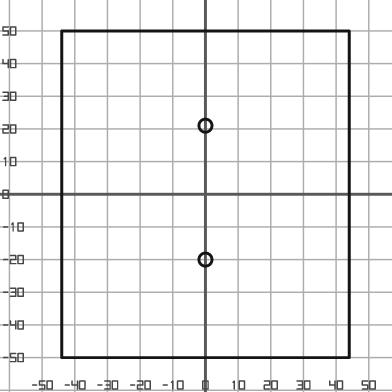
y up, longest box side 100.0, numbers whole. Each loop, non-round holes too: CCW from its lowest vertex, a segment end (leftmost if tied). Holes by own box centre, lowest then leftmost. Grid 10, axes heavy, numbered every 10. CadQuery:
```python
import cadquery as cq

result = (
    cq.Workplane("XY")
    .moveTo(-44.0, -50.0)
    .lineTo(44.0, -50.0)
    .lineTo(44.0, 50.0)
    .lineTo(-44.0, 50.0)
    .close()
    .moveTo(0.0, -20.0)
    .circle(2.0)
    .moveTo(0.0, 21.0)
    .circle(2.0)
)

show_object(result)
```